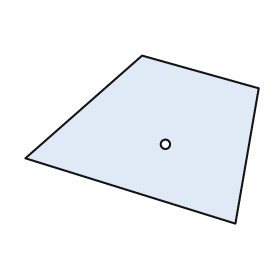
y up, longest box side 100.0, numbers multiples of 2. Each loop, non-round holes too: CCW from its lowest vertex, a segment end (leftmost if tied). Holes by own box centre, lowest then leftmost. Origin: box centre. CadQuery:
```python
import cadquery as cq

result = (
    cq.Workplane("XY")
    .moveTo(40.0, -36.0)
    .lineTo(50.0, 22.0)
    .lineTo(0.0, 36.0)
    .lineTo(-50.0, -8.0)
    .close()
    .moveTo(10.0, -2.0)
    .circle(2.0)
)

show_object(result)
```